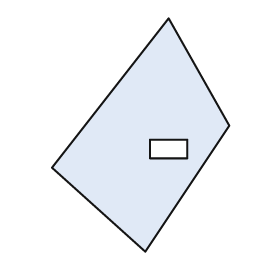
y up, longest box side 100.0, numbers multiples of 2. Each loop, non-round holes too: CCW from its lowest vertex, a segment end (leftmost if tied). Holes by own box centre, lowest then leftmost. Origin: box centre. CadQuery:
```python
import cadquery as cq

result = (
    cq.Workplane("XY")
    .moveTo(2.0, -50.0)
    .lineTo(38.0, 4.0)
    .lineTo(12.0, 50.0)
    .lineTo(-38.0, -14.0)
    .close()
    .moveTo(4.0, -10.0)
    .lineTo(20.0, -10.0)
    .lineTo(20.0, -2.0)
    .lineTo(4.0, -2.0)
    .close()
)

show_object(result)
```